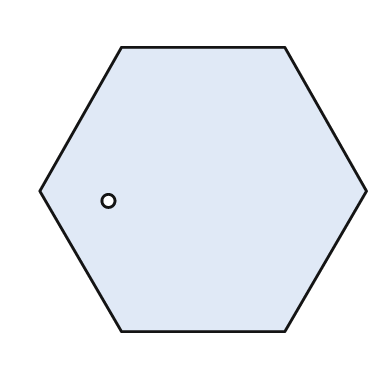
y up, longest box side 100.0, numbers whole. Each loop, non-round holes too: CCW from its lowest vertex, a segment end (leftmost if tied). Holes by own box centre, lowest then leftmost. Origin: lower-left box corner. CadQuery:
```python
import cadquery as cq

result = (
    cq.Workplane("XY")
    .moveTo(25.0, 0.0)
    .lineTo(75.0, 0.0)
    .lineTo(100.0, 43.0)
    .lineTo(75.0, 87.0)
    .lineTo(25.0, 87.0)
    .lineTo(0.0, 43.0)
    .close()
    .moveTo(21.0, 40.0)
    .circle(2.0)
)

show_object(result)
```